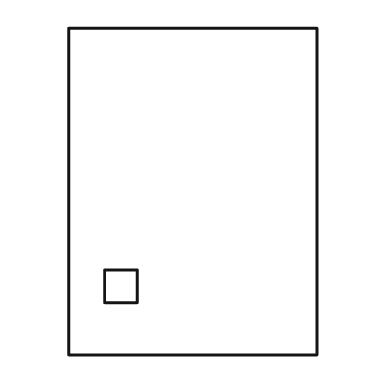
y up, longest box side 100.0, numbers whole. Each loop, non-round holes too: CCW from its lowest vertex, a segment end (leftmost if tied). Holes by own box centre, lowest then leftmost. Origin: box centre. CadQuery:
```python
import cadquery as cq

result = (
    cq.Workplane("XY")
    .moveTo(-38.0, -50.0)
    .lineTo(38.0, -50.0)
    .lineTo(38.0, 50.0)
    .lineTo(-38.0, 50.0)
    .close()
    .moveTo(-27.0, -34.0)
    .lineTo(-17.0, -34.0)
    .lineTo(-17.0, -24.0)
    .lineTo(-27.0, -24.0)
    .close()
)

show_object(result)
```